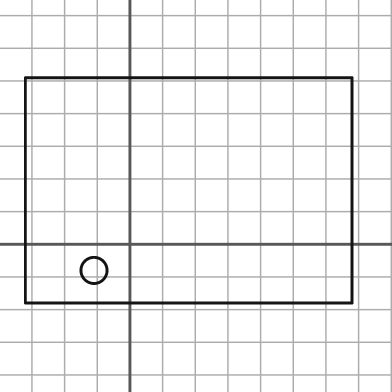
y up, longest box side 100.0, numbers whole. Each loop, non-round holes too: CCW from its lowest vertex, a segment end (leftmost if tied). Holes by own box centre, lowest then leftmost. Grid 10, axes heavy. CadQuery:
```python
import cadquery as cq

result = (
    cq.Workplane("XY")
    .moveTo(-32.0, -18.0)
    .lineTo(68.0, -18.0)
    .lineTo(68.0, 51.0)
    .lineTo(-32.0, 51.0)
    .close()
    .moveTo(-11.0, -8.0)
    .circle(4.0)
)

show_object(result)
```